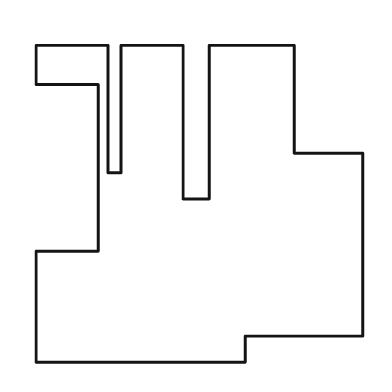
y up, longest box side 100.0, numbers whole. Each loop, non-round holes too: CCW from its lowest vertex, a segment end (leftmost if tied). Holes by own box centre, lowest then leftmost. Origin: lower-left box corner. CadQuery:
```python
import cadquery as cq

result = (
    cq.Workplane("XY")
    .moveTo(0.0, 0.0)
    .lineTo(64.0, 0.0)
    .lineTo(64.0, 8.0)
    .lineTo(100.0, 8.0)
    .lineTo(100.0, 64.0)
    .lineTo(79.0, 64.0)
    .lineTo(79.0, 97.0)
    .lineTo(53.0, 97.0)
    .lineTo(53.0, 50.0)
    .lineTo(45.0, 50.0)
    .lineTo(45.0, 97.0)
    .lineTo(26.0, 97.0)
    .lineTo(26.0, 58.0)
    .lineTo(22.0, 58.0)
    .lineTo(22.0, 97.0)
    .lineTo(0.0, 97.0)
    .lineTo(0.0, 85.0)
    .lineTo(19.0, 85.0)
    .lineTo(19.0, 34.0)
    .lineTo(0.0, 34.0)
    .close()
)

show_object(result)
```